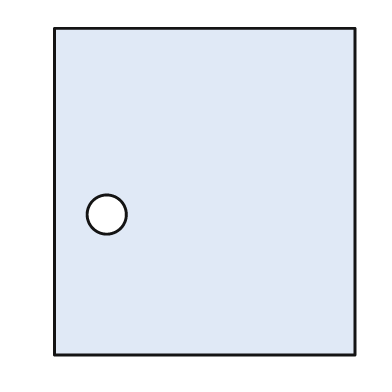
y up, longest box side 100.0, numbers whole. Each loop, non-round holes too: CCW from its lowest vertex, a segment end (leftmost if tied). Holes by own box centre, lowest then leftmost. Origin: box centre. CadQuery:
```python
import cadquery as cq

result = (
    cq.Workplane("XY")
    .moveTo(-46.0, -50.0)
    .lineTo(46.0, -50.0)
    .lineTo(46.0, 50.0)
    .lineTo(-46.0, 50.0)
    .close()
    .moveTo(-30.0, -7.0)
    .circle(6.0)
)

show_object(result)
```